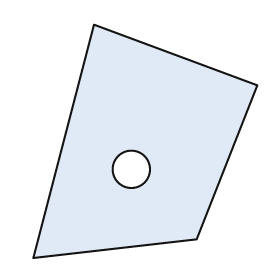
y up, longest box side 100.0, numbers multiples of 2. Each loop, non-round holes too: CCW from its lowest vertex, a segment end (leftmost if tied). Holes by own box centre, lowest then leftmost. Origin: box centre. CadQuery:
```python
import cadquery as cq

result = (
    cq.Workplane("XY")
    .moveTo(-48.0, -50.0)
    .lineTo(22.0, -42.0)
    .lineTo(48.0, 24.0)
    .lineTo(-22.0, 50.0)
    .close()
    .moveTo(-6.0, -12.0)
    .circle(8.0)
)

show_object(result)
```